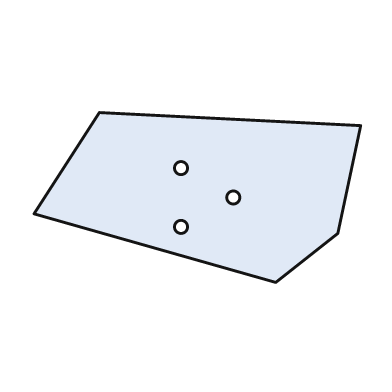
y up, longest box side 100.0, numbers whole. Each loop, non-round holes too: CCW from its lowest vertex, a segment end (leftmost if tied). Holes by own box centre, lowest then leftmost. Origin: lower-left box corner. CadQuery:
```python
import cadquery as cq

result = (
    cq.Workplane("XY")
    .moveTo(74.0, 0.0)
    .lineTo(93.0, 15.0)
    .lineTo(100.0, 48.0)
    .lineTo(20.0, 52.0)
    .lineTo(0.0, 21.0)
    .close()
    .moveTo(45.0, 17.0)
    .circle(2.0)
    .moveTo(61.0, 26.0)
    .circle(2.0)
    .moveTo(45.0, 35.0)
    .circle(2.0)
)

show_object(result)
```